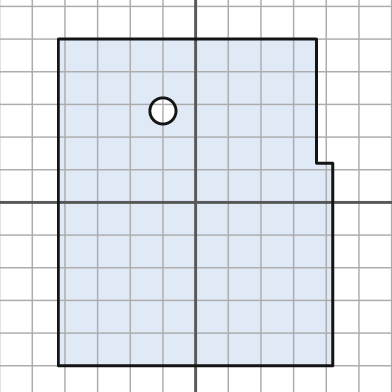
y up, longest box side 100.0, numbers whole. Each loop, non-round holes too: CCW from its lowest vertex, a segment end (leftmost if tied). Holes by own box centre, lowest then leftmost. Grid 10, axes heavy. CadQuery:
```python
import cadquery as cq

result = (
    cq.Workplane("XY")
    .moveTo(-42.0, -50.0)
    .lineTo(42.0, -50.0)
    .lineTo(42.0, 12.0)
    .lineTo(37.0, 12.0)
    .lineTo(37.0, 50.0)
    .lineTo(-42.0, 50.0)
    .close()
    .moveTo(-10.0, 28.0)
    .circle(4.0)
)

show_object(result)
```